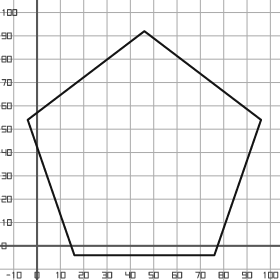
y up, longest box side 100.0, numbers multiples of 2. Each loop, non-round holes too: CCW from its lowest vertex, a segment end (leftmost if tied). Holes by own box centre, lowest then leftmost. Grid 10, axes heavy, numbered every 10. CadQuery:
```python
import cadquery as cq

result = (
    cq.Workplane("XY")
    .moveTo(16.0, -4.0)
    .lineTo(76.0, -4.0)
    .lineTo(96.0, 54.0)
    .lineTo(46.0, 92.0)
    .lineTo(-4.0, 54.0)
    .close()
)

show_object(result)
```